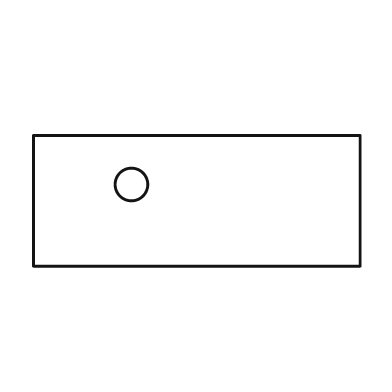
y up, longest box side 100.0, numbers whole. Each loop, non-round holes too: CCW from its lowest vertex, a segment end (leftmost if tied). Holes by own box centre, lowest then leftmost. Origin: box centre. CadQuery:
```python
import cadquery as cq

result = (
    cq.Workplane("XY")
    .moveTo(-50.0, -20.0)
    .lineTo(50.0, -20.0)
    .lineTo(50.0, 20.0)
    .lineTo(-50.0, 20.0)
    .close()
    .moveTo(-20.0, 5.0)
    .circle(5.0)
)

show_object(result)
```